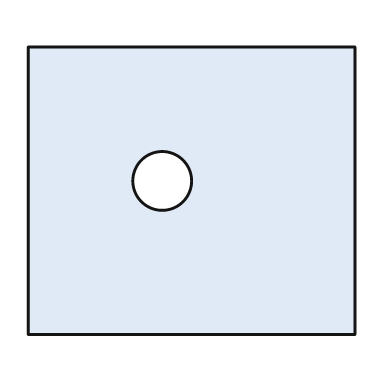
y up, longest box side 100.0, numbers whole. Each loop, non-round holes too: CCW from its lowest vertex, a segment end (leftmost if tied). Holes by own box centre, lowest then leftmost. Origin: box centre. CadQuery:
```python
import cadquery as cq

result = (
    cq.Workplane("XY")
    .moveTo(-50.0, -44.0)
    .lineTo(50.0, -44.0)
    .lineTo(50.0, 44.0)
    .lineTo(-50.0, 44.0)
    .close()
    .moveTo(-9.0, 3.0)
    .circle(9.0)
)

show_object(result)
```